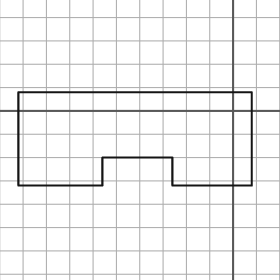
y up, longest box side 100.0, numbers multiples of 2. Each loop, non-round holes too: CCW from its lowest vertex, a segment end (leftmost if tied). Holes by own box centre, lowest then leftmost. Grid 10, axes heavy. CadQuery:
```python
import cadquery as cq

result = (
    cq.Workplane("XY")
    .moveTo(-92.0, -32.0)
    .lineTo(-56.0, -32.0)
    .lineTo(-56.0, -20.0)
    .lineTo(-26.0, -20.0)
    .lineTo(-26.0, -32.0)
    .lineTo(8.0, -32.0)
    .lineTo(8.0, 8.0)
    .lineTo(-92.0, 8.0)
    .close()
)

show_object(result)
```